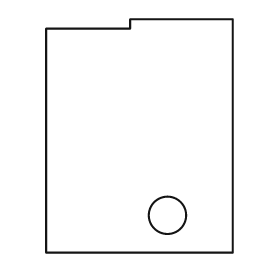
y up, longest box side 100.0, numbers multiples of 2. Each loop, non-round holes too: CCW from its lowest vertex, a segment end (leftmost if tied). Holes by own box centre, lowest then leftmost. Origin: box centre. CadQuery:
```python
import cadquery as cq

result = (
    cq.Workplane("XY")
    .moveTo(-40.0, -50.0)
    .lineTo(40.0, -50.0)
    .lineTo(40.0, 50.0)
    .lineTo(-4.0, 50.0)
    .lineTo(-4.0, 46.0)
    .lineTo(-40.0, 46.0)
    .close()
    .moveTo(12.0, -34.0)
    .circle(8.0)
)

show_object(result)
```